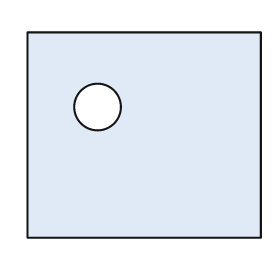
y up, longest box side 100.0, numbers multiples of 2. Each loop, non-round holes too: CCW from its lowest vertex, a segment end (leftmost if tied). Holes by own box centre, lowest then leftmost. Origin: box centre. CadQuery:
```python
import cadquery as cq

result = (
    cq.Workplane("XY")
    .moveTo(-50.0, -44.0)
    .lineTo(50.0, -44.0)
    .lineTo(50.0, 44.0)
    .lineTo(-50.0, 44.0)
    .close()
    .moveTo(-20.0, 12.0)
    .circle(10.0)
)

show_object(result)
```